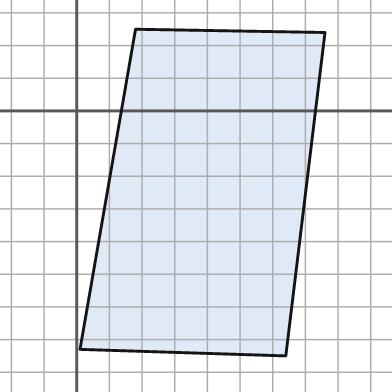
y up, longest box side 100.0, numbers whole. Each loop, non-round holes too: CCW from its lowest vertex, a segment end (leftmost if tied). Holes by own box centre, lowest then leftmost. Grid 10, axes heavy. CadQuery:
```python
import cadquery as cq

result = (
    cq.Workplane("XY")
    .moveTo(64.0, -75.0)
    .lineTo(76.0, 24.0)
    .lineTo(18.0, 25.0)
    .lineTo(1.0, -73.0)
    .close()
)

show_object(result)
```